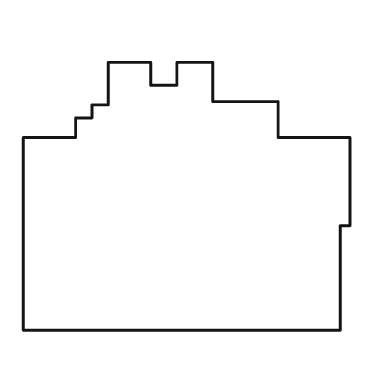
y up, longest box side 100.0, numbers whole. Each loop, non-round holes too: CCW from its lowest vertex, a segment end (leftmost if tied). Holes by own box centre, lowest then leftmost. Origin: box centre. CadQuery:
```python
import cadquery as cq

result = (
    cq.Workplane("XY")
    .moveTo(-50.0, -41.0)
    .lineTo(47.0, -41.0)
    .lineTo(47.0, -9.0)
    .lineTo(50.0, -9.0)
    .lineTo(50.0, 18.0)
    .lineTo(28.0, 18.0)
    .lineTo(28.0, 29.0)
    .lineTo(8.0, 29.0)
    .lineTo(8.0, 41.0)
    .lineTo(-3.0, 41.0)
    .lineTo(-3.0, 34.0)
    .lineTo(-11.0, 34.0)
    .lineTo(-11.0, 41.0)
    .lineTo(-24.0, 41.0)
    .lineTo(-24.0, 28.0)
    .lineTo(-29.0, 28.0)
    .lineTo(-29.0, 24.0)
    .lineTo(-34.0, 24.0)
    .lineTo(-34.0, 18.0)
    .lineTo(-50.0, 18.0)
    .close()
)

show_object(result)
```